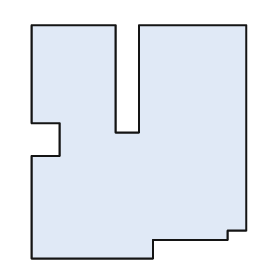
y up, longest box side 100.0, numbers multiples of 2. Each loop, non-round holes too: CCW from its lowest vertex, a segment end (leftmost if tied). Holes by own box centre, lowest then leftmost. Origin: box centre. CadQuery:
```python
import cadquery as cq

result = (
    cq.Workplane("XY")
    .moveTo(-46.0, -50.0)
    .lineTo(6.0, -50.0)
    .lineTo(6.0, -42.0)
    .lineTo(38.0, -42.0)
    .lineTo(38.0, -38.0)
    .lineTo(46.0, -38.0)
    .lineTo(46.0, 50.0)
    .lineTo(0.0, 50.0)
    .lineTo(0.0, 4.0)
    .lineTo(-10.0, 4.0)
    .lineTo(-10.0, 50.0)
    .lineTo(-46.0, 50.0)
    .lineTo(-46.0, 8.0)
    .lineTo(-34.0, 8.0)
    .lineTo(-34.0, -6.0)
    .lineTo(-46.0, -6.0)
    .close()
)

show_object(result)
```